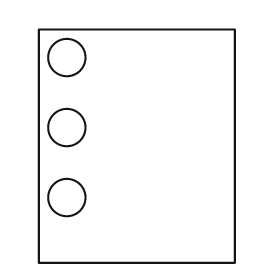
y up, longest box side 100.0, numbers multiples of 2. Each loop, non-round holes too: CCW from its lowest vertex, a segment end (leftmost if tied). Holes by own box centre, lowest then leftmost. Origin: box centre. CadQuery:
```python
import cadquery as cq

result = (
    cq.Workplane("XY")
    .moveTo(-42.0, -50.0)
    .lineTo(42.0, -50.0)
    .lineTo(42.0, 50.0)
    .lineTo(-42.0, 50.0)
    .close()
    .moveTo(-30.0, -22.0)
    .circle(8.0)
    .moveTo(-30.0, 8.0)
    .circle(8.0)
    .moveTo(-30.0, 38.0)
    .circle(8.0)
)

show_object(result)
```